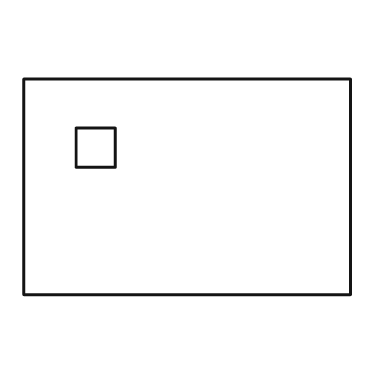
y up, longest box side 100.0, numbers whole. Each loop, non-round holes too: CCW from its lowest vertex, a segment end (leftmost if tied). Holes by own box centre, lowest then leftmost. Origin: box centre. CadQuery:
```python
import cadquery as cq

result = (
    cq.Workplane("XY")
    .moveTo(-50.0, -33.0)
    .lineTo(50.0, -33.0)
    .lineTo(50.0, 33.0)
    .lineTo(-50.0, 33.0)
    .close()
    .moveTo(-34.0, 6.0)
    .lineTo(-22.0, 6.0)
    .lineTo(-22.0, 18.0)
    .lineTo(-34.0, 18.0)
    .close()
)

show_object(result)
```